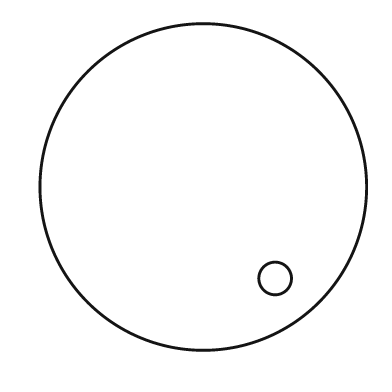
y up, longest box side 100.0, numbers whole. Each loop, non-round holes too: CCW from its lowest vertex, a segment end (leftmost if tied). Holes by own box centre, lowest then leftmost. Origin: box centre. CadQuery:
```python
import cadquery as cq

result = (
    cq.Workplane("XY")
    .moveTo(0.0, 0.0)
    .circle(50.0)
    .moveTo(22.0, -28.0)
    .circle(5.0)
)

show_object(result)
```